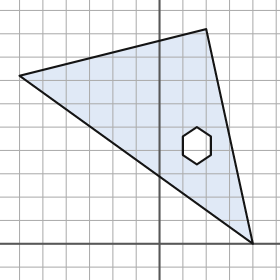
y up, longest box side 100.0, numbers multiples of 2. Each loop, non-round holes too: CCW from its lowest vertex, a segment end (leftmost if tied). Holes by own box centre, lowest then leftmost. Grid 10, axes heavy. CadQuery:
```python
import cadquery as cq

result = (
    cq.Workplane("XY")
    .moveTo(40.0, 0.0)
    .lineTo(20.0, 92.0)
    .lineTo(-60.0, 72.0)
    .close()
    .moveTo(16.0, 34.0)
    .lineTo(22.0, 38.0)
    .lineTo(22.0, 46.0)
    .lineTo(16.0, 50.0)
    .lineTo(10.0, 46.0)
    .lineTo(10.0, 38.0)
    .close()
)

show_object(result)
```